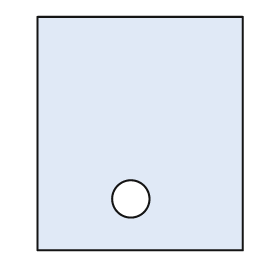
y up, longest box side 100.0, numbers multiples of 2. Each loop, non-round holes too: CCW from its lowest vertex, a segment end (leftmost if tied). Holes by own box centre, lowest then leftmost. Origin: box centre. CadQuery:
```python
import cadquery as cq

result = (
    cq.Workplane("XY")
    .moveTo(-44.0, -50.0)
    .lineTo(44.0, -50.0)
    .lineTo(44.0, 50.0)
    .lineTo(-44.0, 50.0)
    .close()
    .moveTo(-4.0, -28.0)
    .circle(8.0)
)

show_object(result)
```